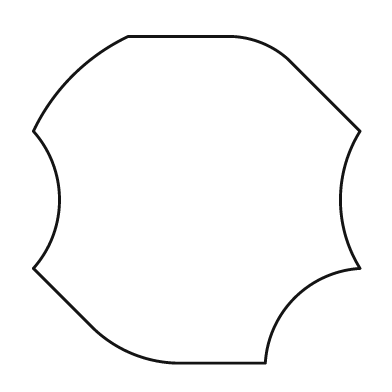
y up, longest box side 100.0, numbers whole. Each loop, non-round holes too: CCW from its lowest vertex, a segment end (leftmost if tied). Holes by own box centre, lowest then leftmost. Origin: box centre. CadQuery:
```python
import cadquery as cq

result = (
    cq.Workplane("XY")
    .moveTo(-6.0, -50.0)
    .lineTo(21.0, -50.0)
    .threePointArc((30.0, -30.0), (50.0, -21.0))
    .threePointArc((44.0, 0.0), (50.0, 21.0))
    .lineTo(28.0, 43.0)
    .threePointArc((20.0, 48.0), (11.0, 50.0))
    .lineTo(-21.0, 50.0)
    .threePointArc((-38.0, 38.0), (-50.0, 21.0))
    .threePointArc((-42.0, 0.0), (-50.0, -21.0))
    .lineTo(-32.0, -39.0)
    .threePointArc((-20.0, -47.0), (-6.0, -50.0))
    .close()
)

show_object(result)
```